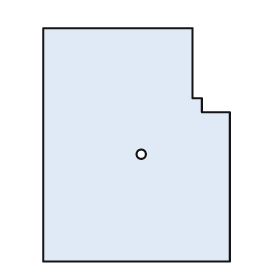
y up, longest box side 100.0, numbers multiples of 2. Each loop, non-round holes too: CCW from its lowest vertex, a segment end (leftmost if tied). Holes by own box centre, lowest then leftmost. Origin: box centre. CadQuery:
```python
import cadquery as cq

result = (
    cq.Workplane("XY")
    .moveTo(-40.0, -50.0)
    .lineTo(40.0, -50.0)
    .lineTo(40.0, 14.0)
    .lineTo(28.0, 14.0)
    .lineTo(28.0, 20.0)
    .lineTo(24.0, 20.0)
    .lineTo(24.0, 50.0)
    .lineTo(-40.0, 50.0)
    .close()
    .moveTo(2.0, -4.0)
    .circle(2.0)
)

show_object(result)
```